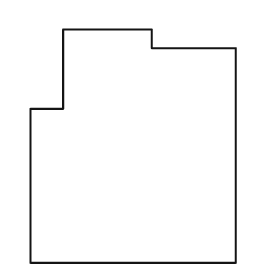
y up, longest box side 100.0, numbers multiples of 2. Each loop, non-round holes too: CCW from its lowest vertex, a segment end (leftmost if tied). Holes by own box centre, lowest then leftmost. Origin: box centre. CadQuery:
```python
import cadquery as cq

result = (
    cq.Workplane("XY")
    .moveTo(-44.0, -50.0)
    .lineTo(44.0, -50.0)
    .lineTo(44.0, 42.0)
    .lineTo(8.0, 42.0)
    .lineTo(8.0, 50.0)
    .lineTo(-30.0, 50.0)
    .lineTo(-30.0, 16.0)
    .lineTo(-44.0, 16.0)
    .close()
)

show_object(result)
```